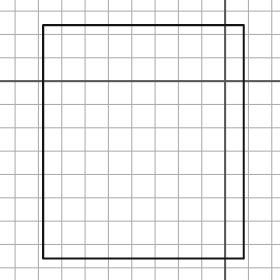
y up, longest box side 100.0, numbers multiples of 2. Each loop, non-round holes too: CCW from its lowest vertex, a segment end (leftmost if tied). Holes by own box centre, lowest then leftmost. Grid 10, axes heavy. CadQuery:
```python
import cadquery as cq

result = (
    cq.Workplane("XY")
    .moveTo(-78.0, -76.0)
    .lineTo(8.0, -76.0)
    .lineTo(8.0, 24.0)
    .lineTo(-78.0, 24.0)
    .close()
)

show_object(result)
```